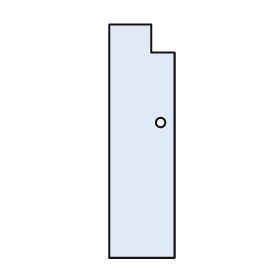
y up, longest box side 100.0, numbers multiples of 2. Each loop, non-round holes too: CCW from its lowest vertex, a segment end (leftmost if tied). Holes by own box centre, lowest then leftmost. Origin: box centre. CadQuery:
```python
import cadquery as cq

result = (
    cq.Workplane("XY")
    .moveTo(-14.0, -50.0)
    .lineTo(14.0, -50.0)
    .lineTo(14.0, 38.0)
    .lineTo(4.0, 38.0)
    .lineTo(4.0, 50.0)
    .lineTo(-14.0, 50.0)
    .close()
    .moveTo(8.0, 8.0)
    .circle(2.0)
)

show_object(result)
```